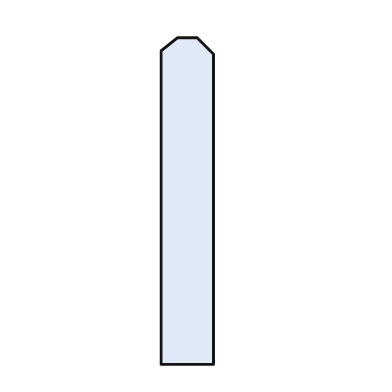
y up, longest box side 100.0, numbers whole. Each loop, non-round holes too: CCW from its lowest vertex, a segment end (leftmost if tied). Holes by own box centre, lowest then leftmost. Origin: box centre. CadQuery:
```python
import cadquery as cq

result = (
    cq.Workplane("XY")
    .moveTo(-8.0, -50.0)
    .lineTo(8.0, -50.0)
    .lineTo(8.0, 45.0)
    .lineTo(3.0, 50.0)
    .lineTo(-3.0, 50.0)
    .lineTo(-8.0, 46.0)
    .close()
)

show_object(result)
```